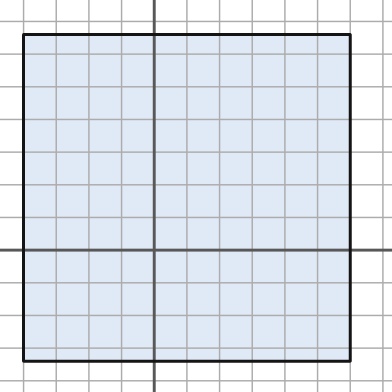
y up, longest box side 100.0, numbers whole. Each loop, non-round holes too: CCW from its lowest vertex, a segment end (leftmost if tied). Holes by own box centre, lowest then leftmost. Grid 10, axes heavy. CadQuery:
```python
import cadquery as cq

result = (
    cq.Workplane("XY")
    .moveTo(-40.0, -34.0)
    .lineTo(60.0, -34.0)
    .lineTo(60.0, 66.0)
    .lineTo(-40.0, 66.0)
    .close()
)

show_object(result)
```